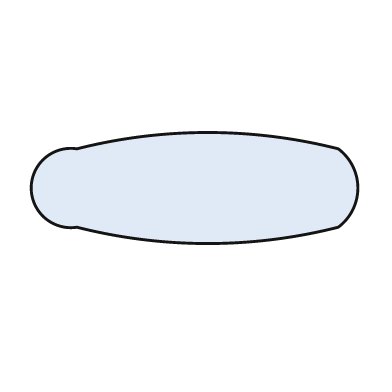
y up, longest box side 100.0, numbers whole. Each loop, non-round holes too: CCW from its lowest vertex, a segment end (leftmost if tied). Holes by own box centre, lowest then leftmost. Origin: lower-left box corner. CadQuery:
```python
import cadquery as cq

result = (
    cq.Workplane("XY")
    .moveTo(14.0, 5.0)
    .threePointArc((54.0, 0.0), (94.0, 5.0))
    .threePointArc((100.0, 17.0), (94.0, 29.0))
    .threePointArc((54.0, 34.0), (14.0, 29.0))
    .threePointArc((0.0, 17.0), (14.0, 5.0))
    .close()
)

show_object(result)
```